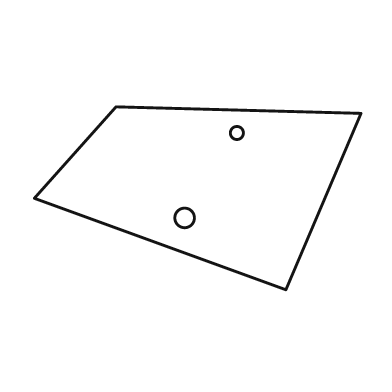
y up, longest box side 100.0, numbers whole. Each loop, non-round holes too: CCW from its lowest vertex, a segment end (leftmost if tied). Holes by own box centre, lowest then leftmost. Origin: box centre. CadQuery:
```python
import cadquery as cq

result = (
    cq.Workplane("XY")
    .moveTo(27.0, -28.0)
    .lineTo(50.0, 26.0)
    .lineTo(-25.0, 28.0)
    .lineTo(-50.0, 0.0)
    .close()
    .moveTo(-4.0, -6.0)
    .circle(3.0)
    .moveTo(12.0, 20.0)
    .circle(2.0)
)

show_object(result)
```